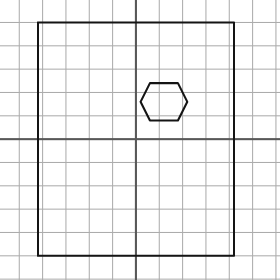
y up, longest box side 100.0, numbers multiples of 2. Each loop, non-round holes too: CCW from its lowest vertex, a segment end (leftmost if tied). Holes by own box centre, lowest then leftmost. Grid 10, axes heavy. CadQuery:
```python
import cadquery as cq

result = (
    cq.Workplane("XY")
    .moveTo(-42.0, -50.0)
    .lineTo(42.0, -50.0)
    .lineTo(42.0, 50.0)
    .lineTo(-42.0, 50.0)
    .close()
    .moveTo(6.0, 8.0)
    .lineTo(18.0, 8.0)
    .lineTo(22.0, 16.0)
    .lineTo(18.0, 24.0)
    .lineTo(6.0, 24.0)
    .lineTo(2.0, 16.0)
    .close()
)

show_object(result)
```